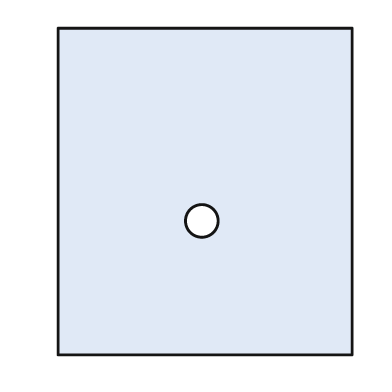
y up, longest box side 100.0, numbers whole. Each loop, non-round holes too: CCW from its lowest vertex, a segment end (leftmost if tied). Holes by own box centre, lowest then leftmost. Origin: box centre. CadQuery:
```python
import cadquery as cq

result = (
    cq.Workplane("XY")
    .moveTo(-45.0, -50.0)
    .lineTo(45.0, -50.0)
    .lineTo(45.0, 50.0)
    .lineTo(-45.0, 50.0)
    .close()
    .moveTo(-1.0, -9.0)
    .circle(5.0)
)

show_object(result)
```